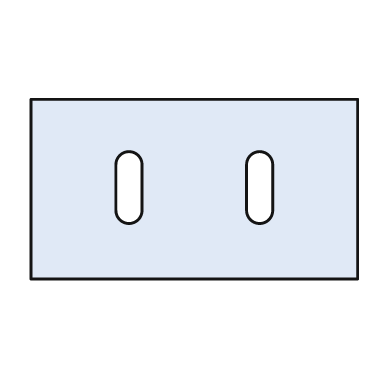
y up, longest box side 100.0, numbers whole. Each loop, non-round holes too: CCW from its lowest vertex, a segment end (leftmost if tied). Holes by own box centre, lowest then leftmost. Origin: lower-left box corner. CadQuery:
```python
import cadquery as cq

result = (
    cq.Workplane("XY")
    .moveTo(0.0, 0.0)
    .lineTo(100.0, 0.0)
    .lineTo(100.0, 55.0)
    .lineTo(0.0, 55.0)
    .close()
    .moveTo(26.0, 21.0)
    .threePointArc((30.0, 17.0), (34.0, 21.0))
    .lineTo(34.0, 35.0)
    .threePointArc((30.0, 39.0), (26.0, 35.0))
    .close()
    .moveTo(66.0, 21.0)
    .threePointArc((70.0, 17.0), (74.0, 21.0))
    .lineTo(74.0, 35.0)
    .threePointArc((70.0, 39.0), (66.0, 35.0))
    .close()
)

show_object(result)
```